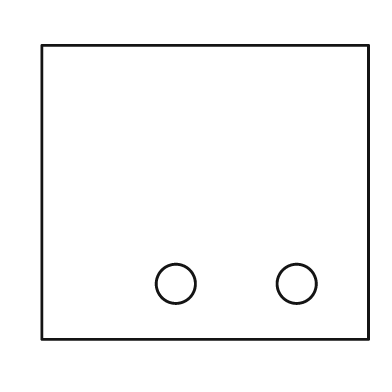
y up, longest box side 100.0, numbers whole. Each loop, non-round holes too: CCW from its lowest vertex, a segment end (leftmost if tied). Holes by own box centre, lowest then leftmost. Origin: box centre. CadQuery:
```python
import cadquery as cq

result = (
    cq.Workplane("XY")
    .moveTo(-50.0, -45.0)
    .lineTo(50.0, -45.0)
    .lineTo(50.0, 45.0)
    .lineTo(-50.0, 45.0)
    .close()
    .moveTo(-9.0, -28.0)
    .circle(6.0)
    .moveTo(28.0, -28.0)
    .circle(6.0)
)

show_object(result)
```